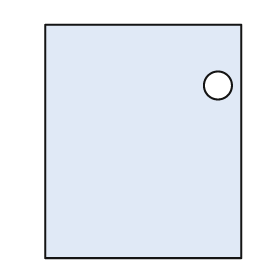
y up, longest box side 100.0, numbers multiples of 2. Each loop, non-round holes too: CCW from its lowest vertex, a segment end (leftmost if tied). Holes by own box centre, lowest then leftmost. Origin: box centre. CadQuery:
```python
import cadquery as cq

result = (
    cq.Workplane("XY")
    .moveTo(-42.0, -50.0)
    .lineTo(42.0, -50.0)
    .lineTo(42.0, 50.0)
    .lineTo(-42.0, 50.0)
    .close()
    .moveTo(32.0, 24.0)
    .circle(6.0)
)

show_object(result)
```